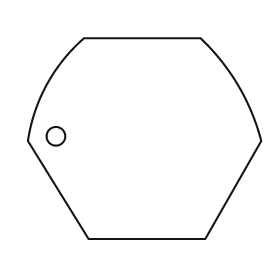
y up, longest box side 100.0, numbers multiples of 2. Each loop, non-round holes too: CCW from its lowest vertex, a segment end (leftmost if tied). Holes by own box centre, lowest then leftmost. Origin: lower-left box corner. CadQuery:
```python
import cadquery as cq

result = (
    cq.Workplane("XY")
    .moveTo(26.0, 0.0)
    .lineTo(76.0, 0.0)
    .lineTo(100.0, 42.0)
    .threePointArc((90.0, 66.0), (74.0, 86.0))
    .lineTo(24.0, 86.0)
    .threePointArc((8.0, 66.0), (0.0, 42.0))
    .close()
    .moveTo(12.0, 44.0)
    .circle(4.0)
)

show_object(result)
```